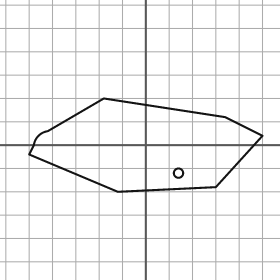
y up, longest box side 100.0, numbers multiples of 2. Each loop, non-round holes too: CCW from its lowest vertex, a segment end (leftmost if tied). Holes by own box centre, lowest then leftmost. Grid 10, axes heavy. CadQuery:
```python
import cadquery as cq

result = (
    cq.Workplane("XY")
    .moveTo(-12.0, -20.0)
    .lineTo(30.0, -18.0)
    .lineTo(50.0, 4.0)
    .lineTo(34.0, 12.0)
    .lineTo(-18.0, 20.0)
    .lineTo(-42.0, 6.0)
    .threePointArc((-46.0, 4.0), (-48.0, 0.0))
    .lineTo(-50.0, -4.0)
    .close()
    .moveTo(14.0, -12.0)
    .circle(2.0)
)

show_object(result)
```